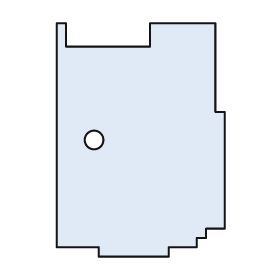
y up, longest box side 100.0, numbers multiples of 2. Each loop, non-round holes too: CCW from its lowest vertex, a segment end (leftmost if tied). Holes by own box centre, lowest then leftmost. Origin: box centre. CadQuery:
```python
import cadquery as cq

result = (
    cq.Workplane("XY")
    .moveTo(-18.0, -50.0)
    .lineTo(12.0, -50.0)
    .lineTo(12.0, -46.0)
    .lineTo(24.0, -46.0)
    .lineTo(24.0, -42.0)
    .lineTo(28.0, -42.0)
    .lineTo(28.0, -38.0)
    .lineTo(36.0, -38.0)
    .lineTo(36.0, 12.0)
    .lineTo(32.0, 12.0)
    .lineTo(32.0, 50.0)
    .lineTo(4.0, 50.0)
    .lineTo(4.0, 40.0)
    .lineTo(-32.0, 40.0)
    .lineTo(-32.0, 50.0)
    .lineTo(-36.0, 50.0)
    .lineTo(-36.0, -46.0)
    .lineTo(-18.0, -46.0)
    .close()
    .moveTo(-20.0, 0.0)
    .circle(4.0)
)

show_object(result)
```